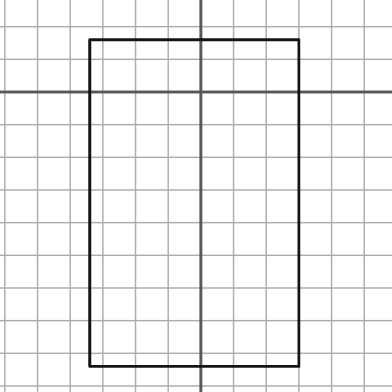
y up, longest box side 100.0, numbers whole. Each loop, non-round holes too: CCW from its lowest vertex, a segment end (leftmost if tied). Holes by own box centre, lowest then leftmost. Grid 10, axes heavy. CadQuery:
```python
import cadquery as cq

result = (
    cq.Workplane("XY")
    .moveTo(-34.0, -84.0)
    .lineTo(30.0, -84.0)
    .lineTo(30.0, 16.0)
    .lineTo(-34.0, 16.0)
    .close()
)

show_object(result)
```